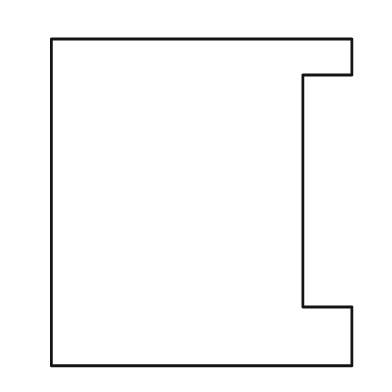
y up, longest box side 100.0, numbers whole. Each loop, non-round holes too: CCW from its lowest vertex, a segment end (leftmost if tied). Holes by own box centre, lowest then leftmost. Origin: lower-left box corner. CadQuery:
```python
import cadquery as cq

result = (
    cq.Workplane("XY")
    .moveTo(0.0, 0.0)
    .lineTo(92.0, 0.0)
    .lineTo(92.0, 18.0)
    .lineTo(77.0, 18.0)
    .lineTo(77.0, 89.0)
    .lineTo(92.0, 89.0)
    .lineTo(92.0, 100.0)
    .lineTo(0.0, 100.0)
    .close()
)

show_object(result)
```